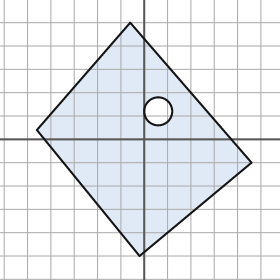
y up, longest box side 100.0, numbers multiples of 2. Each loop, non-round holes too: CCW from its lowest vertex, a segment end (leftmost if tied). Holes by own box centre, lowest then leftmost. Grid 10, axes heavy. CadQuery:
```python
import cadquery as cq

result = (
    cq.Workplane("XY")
    .moveTo(-2.0, -50.0)
    .lineTo(46.0, -10.0)
    .lineTo(-6.0, 50.0)
    .lineTo(-46.0, 4.0)
    .close()
    .moveTo(6.0, 12.0)
    .circle(6.0)
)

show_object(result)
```